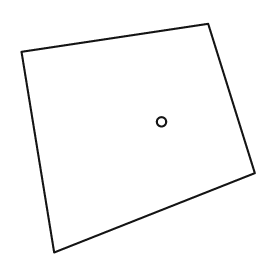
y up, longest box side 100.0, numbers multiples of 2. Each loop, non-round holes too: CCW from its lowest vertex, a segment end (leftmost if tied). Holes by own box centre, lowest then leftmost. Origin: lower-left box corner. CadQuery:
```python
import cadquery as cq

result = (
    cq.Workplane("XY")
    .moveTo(14.0, 0.0)
    .lineTo(100.0, 34.0)
    .lineTo(80.0, 98.0)
    .lineTo(0.0, 86.0)
    .close()
    .moveTo(60.0, 56.0)
    .circle(2.0)
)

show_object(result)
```